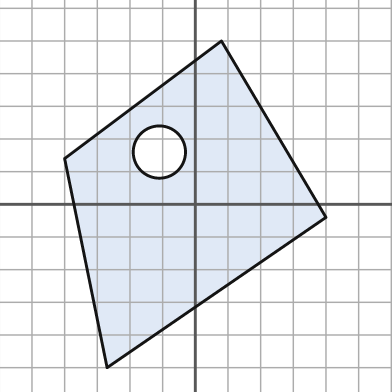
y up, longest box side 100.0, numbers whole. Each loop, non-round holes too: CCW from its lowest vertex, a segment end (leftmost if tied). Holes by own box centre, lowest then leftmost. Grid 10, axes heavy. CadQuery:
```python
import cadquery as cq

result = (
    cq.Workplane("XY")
    .moveTo(-27.0, -50.0)
    .lineTo(40.0, -4.0)
    .lineTo(8.0, 50.0)
    .lineTo(-40.0, 14.0)
    .close()
    .moveTo(-11.0, 16.0)
    .circle(8.0)
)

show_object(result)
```